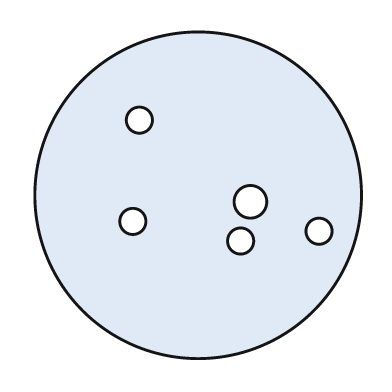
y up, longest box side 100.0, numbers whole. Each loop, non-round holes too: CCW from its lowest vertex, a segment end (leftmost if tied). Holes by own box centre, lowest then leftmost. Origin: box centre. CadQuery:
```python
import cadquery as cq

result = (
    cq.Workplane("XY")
    .moveTo(0.0, 0.0)
    .circle(50.0)
    .moveTo(13.0, -14.0)
    .circle(4.0)
    .moveTo(37.0, -11.0)
    .circle(4.0)
    .moveTo(-20.0, -8.0)
    .circle(4.0)
    .moveTo(16.0, -2.0)
    .circle(5.0)
    .moveTo(-18.0, 23.0)
    .circle(4.0)
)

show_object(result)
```